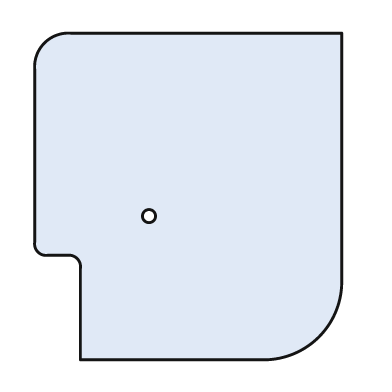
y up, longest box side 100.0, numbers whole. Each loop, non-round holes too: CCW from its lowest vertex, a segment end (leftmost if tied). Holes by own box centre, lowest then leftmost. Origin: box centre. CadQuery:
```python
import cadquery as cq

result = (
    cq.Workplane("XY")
    .moveTo(-33.0, -50.0)
    .lineTo(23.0, -50.0)
    .threePointArc((40.0, -43.0), (47.0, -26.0))
    .lineTo(47.0, 50.0)
    .lineTo(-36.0, 50.0)
    .threePointArc((-44.0, 47.0), (-47.0, 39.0))
    .lineTo(-47.0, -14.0)
    .threePointArc((-46.0, -17.0), (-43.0, -18.0))
    .lineTo(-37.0, -18.0)
    .threePointArc((-34.0, -19.0), (-33.0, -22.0))
    .close()
    .moveTo(-12.0, -6.0)
    .circle(2.0)
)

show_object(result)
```